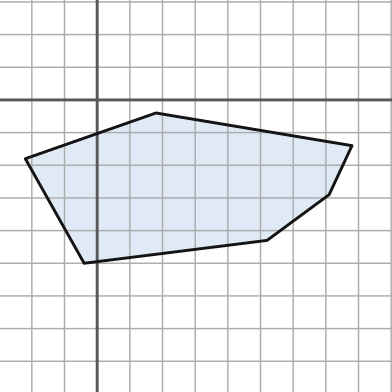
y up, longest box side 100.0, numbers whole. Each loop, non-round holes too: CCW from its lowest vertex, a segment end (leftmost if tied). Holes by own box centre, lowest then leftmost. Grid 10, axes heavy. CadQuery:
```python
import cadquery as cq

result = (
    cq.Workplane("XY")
    .moveTo(-4.0, -50.0)
    .lineTo(52.0, -43.0)
    .lineTo(71.0, -29.0)
    .lineTo(78.0, -14.0)
    .lineTo(18.0, -4.0)
    .lineTo(-22.0, -18.0)
    .close()
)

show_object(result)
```